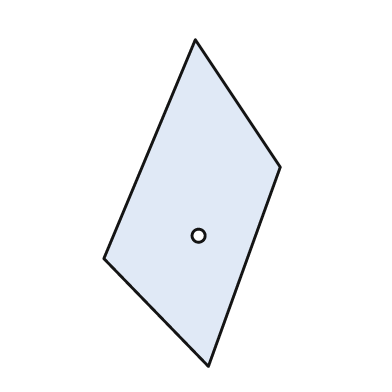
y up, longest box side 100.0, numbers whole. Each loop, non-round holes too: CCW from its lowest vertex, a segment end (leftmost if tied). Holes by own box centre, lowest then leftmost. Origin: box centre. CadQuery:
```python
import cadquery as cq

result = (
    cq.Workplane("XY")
    .moveTo(5.0, -50.0)
    .lineTo(27.0, 11.0)
    .lineTo(1.0, 50.0)
    .lineTo(-27.0, -17.0)
    .close()
    .moveTo(2.0, -10.0)
    .circle(2.0)
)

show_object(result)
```